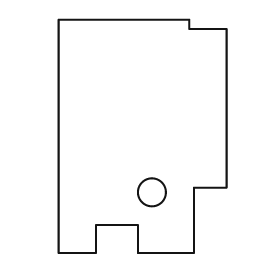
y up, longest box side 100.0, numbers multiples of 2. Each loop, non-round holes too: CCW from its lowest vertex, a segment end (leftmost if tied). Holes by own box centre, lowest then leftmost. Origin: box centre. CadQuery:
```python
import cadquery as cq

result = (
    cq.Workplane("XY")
    .moveTo(-36.0, -50.0)
    .lineTo(-20.0, -50.0)
    .lineTo(-20.0, -38.0)
    .lineTo(-2.0, -38.0)
    .lineTo(-2.0, -50.0)
    .lineTo(22.0, -50.0)
    .lineTo(22.0, -22.0)
    .lineTo(36.0, -22.0)
    .lineTo(36.0, 46.0)
    .lineTo(20.0, 46.0)
    .lineTo(20.0, 50.0)
    .lineTo(-36.0, 50.0)
    .close()
    .moveTo(4.0, -24.0)
    .circle(6.0)
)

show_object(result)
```